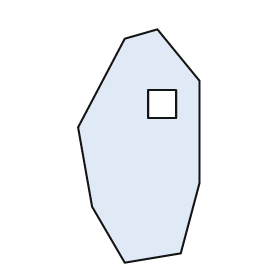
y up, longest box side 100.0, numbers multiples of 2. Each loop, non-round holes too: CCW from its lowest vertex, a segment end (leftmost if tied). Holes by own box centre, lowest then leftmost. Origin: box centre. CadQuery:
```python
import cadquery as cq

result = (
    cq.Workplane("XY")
    .moveTo(-6.0, -50.0)
    .lineTo(18.0, -46.0)
    .lineTo(26.0, -16.0)
    .lineTo(26.0, 28.0)
    .lineTo(8.0, 50.0)
    .lineTo(-6.0, 46.0)
    .lineTo(-26.0, 8.0)
    .lineTo(-20.0, -26.0)
    .close()
    .moveTo(4.0, 12.0)
    .lineTo(16.0, 12.0)
    .lineTo(16.0, 24.0)
    .lineTo(4.0, 24.0)
    .close()
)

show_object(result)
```